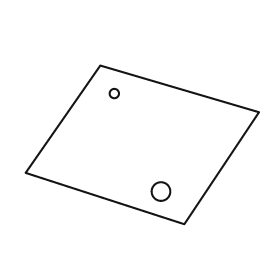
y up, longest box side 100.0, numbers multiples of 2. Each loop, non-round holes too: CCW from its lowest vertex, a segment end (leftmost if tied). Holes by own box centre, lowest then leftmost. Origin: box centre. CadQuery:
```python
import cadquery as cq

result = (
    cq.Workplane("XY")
    .moveTo(18.0, -34.0)
    .lineTo(50.0, 14.0)
    .lineTo(-18.0, 34.0)
    .lineTo(-50.0, -12.0)
    .close()
    .moveTo(8.0, -20.0)
    .circle(4.0)
    .moveTo(-12.0, 22.0)
    .circle(2.0)
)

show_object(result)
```